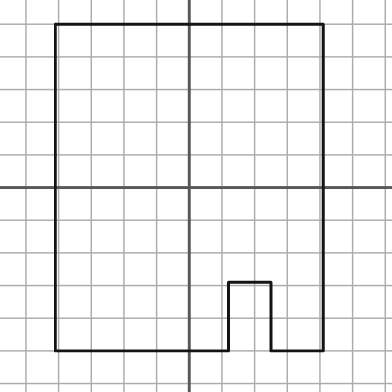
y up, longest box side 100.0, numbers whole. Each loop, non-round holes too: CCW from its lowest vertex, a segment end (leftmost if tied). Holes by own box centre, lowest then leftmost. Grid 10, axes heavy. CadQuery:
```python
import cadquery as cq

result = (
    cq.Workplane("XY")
    .moveTo(-41.0, -50.0)
    .lineTo(12.0, -50.0)
    .lineTo(12.0, -29.0)
    .lineTo(25.0, -29.0)
    .lineTo(25.0, -50.0)
    .lineTo(41.0, -50.0)
    .lineTo(41.0, 50.0)
    .lineTo(-41.0, 50.0)
    .close()
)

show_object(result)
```